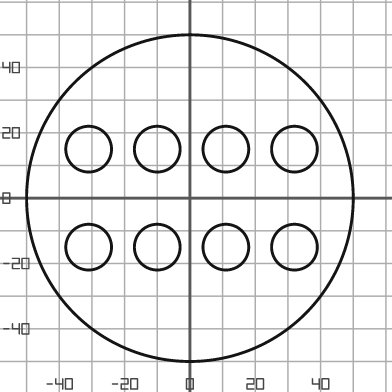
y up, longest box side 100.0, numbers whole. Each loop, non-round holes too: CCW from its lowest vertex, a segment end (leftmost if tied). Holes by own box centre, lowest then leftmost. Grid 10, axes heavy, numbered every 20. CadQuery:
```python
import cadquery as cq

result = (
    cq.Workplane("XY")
    .moveTo(0.0, 0.0)
    .circle(50.0)
    .moveTo(-31.0, -15.0)
    .circle(7.0)
    .moveTo(-10.0, -15.0)
    .circle(7.0)
    .moveTo(11.0, -15.0)
    .circle(7.0)
    .moveTo(32.0, -15.0)
    .circle(7.0)
    .moveTo(-31.0, 15.0)
    .circle(7.0)
    .moveTo(-10.0, 15.0)
    .circle(7.0)
    .moveTo(11.0, 15.0)
    .circle(7.0)
    .moveTo(32.0, 15.0)
    .circle(7.0)
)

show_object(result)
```